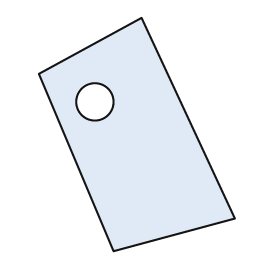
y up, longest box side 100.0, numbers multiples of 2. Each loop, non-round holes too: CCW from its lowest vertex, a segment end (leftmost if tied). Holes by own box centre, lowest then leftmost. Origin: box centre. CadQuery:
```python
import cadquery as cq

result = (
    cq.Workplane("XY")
    .moveTo(-10.0, -50.0)
    .lineTo(42.0, -36.0)
    .lineTo(2.0, 50.0)
    .lineTo(-42.0, 26.0)
    .close()
    .moveTo(-18.0, 14.0)
    .circle(8.0)
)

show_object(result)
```